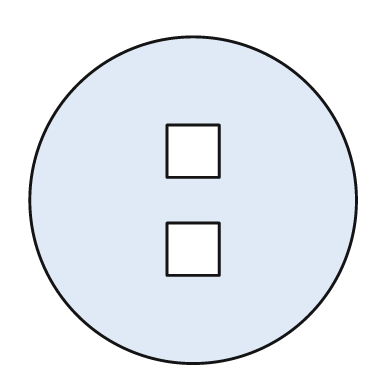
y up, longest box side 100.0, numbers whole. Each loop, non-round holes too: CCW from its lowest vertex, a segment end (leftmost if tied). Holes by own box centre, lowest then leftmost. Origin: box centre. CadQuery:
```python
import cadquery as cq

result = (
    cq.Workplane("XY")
    .moveTo(0.0, 0.0)
    .circle(50.0)
    .moveTo(-8.0, -23.0)
    .lineTo(8.0, -23.0)
    .lineTo(8.0, -7.0)
    .lineTo(-8.0, -7.0)
    .close()
    .moveTo(-8.0, 7.0)
    .lineTo(8.0, 7.0)
    .lineTo(8.0, 23.0)
    .lineTo(-8.0, 23.0)
    .close()
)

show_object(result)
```